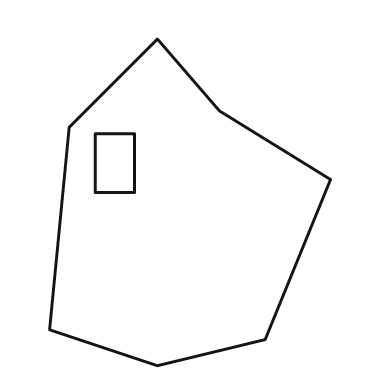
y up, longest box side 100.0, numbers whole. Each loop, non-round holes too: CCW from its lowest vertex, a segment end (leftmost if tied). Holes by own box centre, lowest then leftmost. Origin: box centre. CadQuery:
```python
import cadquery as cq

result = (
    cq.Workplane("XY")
    .moveTo(-10.0, -50.0)
    .lineTo(23.0, -42.0)
    .lineTo(43.0, 7.0)
    .lineTo(9.0, 28.0)
    .lineTo(-10.0, 50.0)
    .lineTo(-37.0, 23.0)
    .lineTo(-43.0, -39.0)
    .close()
    .moveTo(-29.0, 3.0)
    .lineTo(-17.0, 3.0)
    .lineTo(-17.0, 21.0)
    .lineTo(-29.0, 21.0)
    .close()
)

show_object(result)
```